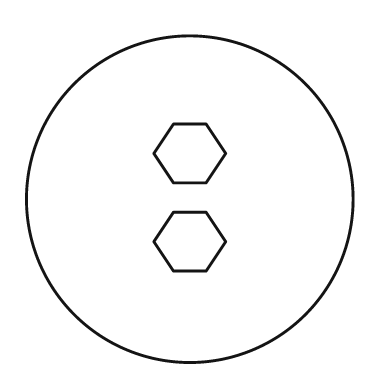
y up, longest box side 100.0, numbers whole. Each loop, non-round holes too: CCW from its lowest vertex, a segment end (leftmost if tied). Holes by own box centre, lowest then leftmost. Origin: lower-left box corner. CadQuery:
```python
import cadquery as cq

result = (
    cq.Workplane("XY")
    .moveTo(50.0, 50.0)
    .circle(50.0)
    .moveTo(45.0, 28.0)
    .lineTo(55.0, 28.0)
    .lineTo(61.0, 37.0)
    .lineTo(55.0, 46.0)
    .lineTo(45.0, 46.0)
    .lineTo(39.0, 37.0)
    .close()
    .moveTo(45.0, 55.0)
    .lineTo(55.0, 55.0)
    .lineTo(61.0, 64.0)
    .lineTo(55.0, 73.0)
    .lineTo(45.0, 73.0)
    .lineTo(39.0, 64.0)
    .close()
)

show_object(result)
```